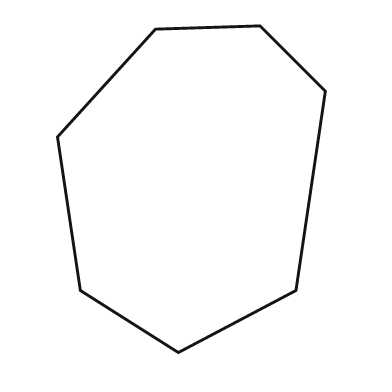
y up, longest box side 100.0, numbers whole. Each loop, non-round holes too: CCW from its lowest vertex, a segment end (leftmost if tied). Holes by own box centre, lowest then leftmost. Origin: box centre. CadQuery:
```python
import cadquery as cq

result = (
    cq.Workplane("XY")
    .moveTo(-4.0, -50.0)
    .lineTo(32.0, -31.0)
    .lineTo(41.0, 30.0)
    .lineTo(21.0, 50.0)
    .lineTo(-11.0, 49.0)
    .lineTo(-41.0, 16.0)
    .lineTo(-34.0, -31.0)
    .close()
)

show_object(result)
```